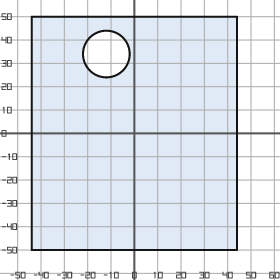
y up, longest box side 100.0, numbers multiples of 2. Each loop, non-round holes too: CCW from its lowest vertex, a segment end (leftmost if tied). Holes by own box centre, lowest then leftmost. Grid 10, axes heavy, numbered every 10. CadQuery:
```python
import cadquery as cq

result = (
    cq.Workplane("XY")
    .moveTo(-44.0, -50.0)
    .lineTo(44.0, -50.0)
    .lineTo(44.0, 50.0)
    .lineTo(-44.0, 50.0)
    .close()
    .moveTo(-12.0, 34.0)
    .circle(10.0)
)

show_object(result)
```